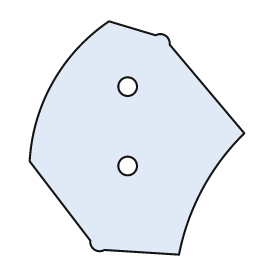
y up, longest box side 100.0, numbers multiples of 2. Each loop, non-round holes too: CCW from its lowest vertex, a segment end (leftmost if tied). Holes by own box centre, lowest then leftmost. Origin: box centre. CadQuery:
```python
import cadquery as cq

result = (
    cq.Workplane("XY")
    .moveTo(18.0, -50.0)
    .threePointArc((28.0, -22.0), (46.0, 2.0))
    .lineTo(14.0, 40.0)
    .threePointArc((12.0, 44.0), (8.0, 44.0))
    .lineTo(-12.0, 50.0)
    .threePointArc((-36.0, 24.0), (-46.0, -10.0))
    .lineTo(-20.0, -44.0)
    .threePointArc((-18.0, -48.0), (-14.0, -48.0))
    .close()
    .moveTo(-4.0, -12.0)
    .circle(4.0)
    .moveTo(-4.0, 22.0)
    .circle(4.0)
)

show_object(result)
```